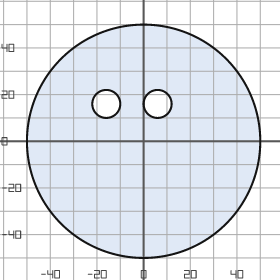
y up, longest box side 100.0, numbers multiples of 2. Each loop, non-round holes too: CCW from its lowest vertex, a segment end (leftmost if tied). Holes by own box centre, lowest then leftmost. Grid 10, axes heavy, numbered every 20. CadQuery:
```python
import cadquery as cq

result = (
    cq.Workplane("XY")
    .moveTo(0.0, 0.0)
    .circle(50.0)
    .moveTo(-16.0, 16.0)
    .circle(6.0)
    .moveTo(6.0, 16.0)
    .circle(6.0)
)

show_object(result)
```